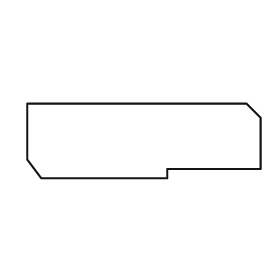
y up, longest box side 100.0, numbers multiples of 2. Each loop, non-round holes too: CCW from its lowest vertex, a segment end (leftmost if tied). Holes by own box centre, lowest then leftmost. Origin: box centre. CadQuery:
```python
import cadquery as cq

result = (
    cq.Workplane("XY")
    .moveTo(-44.0, -16.0)
    .lineTo(10.0, -16.0)
    .lineTo(10.0, -12.0)
    .lineTo(50.0, -12.0)
    .lineTo(50.0, 10.0)
    .lineTo(44.0, 16.0)
    .lineTo(-50.0, 16.0)
    .lineTo(-50.0, -8.0)
    .close()
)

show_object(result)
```